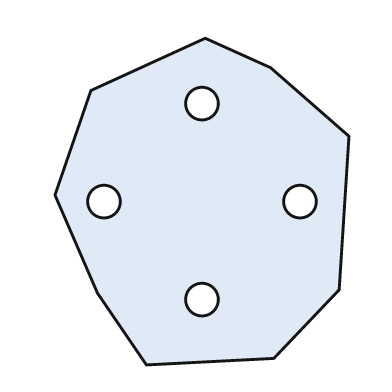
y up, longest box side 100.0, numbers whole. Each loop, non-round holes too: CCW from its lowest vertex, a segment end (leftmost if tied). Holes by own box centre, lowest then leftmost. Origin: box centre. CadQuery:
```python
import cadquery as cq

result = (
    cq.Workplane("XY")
    .moveTo(-17.0, -50.0)
    .lineTo(22.0, -48.0)
    .lineTo(42.0, -27.0)
    .lineTo(45.0, 20.0)
    .lineTo(21.0, 41.0)
    .lineTo(1.0, 50.0)
    .lineTo(-34.0, 34.0)
    .lineTo(-45.0, 2.0)
    .lineTo(-32.0, -28.0)
    .close()
    .moveTo(0.0, -30.0)
    .circle(5.0)
    .moveTo(-30.0, 0.0)
    .circle(5.0)
    .moveTo(30.0, 0.0)
    .circle(5.0)
    .moveTo(0.0, 30.0)
    .circle(5.0)
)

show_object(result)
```